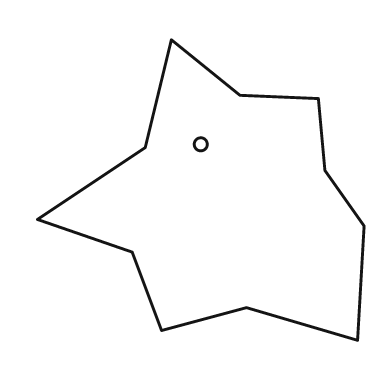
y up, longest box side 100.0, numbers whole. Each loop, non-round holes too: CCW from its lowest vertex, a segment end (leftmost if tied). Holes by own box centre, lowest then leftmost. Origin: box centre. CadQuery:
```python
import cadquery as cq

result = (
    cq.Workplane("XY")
    .moveTo(48.0, -46.0)
    .lineTo(50.0, -11.0)
    .lineTo(38.0, 6.0)
    .lineTo(36.0, 28.0)
    .lineTo(12.0, 29.0)
    .lineTo(-9.0, 46.0)
    .lineTo(-17.0, 13.0)
    .lineTo(-50.0, -9.0)
    .lineTo(-21.0, -19.0)
    .lineTo(-12.0, -43.0)
    .lineTo(14.0, -36.0)
    .close()
    .moveTo(0.0, 14.0)
    .circle(2.0)
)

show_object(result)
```